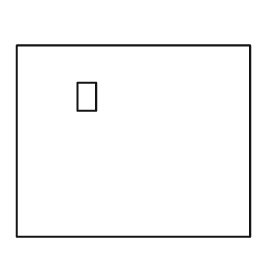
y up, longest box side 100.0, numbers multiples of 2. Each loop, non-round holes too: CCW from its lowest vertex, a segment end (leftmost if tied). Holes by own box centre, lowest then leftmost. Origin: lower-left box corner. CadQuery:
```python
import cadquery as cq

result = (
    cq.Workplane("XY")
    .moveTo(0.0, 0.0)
    .lineTo(100.0, 0.0)
    .lineTo(100.0, 82.0)
    .lineTo(0.0, 82.0)
    .close()
    .moveTo(26.0, 54.0)
    .lineTo(34.0, 54.0)
    .lineTo(34.0, 66.0)
    .lineTo(26.0, 66.0)
    .close()
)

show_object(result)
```